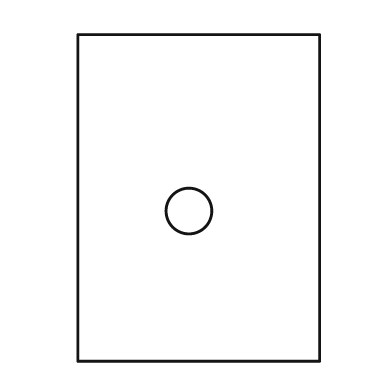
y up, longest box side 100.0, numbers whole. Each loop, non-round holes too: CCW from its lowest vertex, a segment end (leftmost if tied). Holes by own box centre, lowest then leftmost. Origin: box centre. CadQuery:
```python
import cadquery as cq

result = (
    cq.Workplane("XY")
    .moveTo(-37.0, -50.0)
    .lineTo(37.0, -50.0)
    .lineTo(37.0, 50.0)
    .lineTo(-37.0, 50.0)
    .close()
    .moveTo(-3.0, -4.0)
    .circle(7.0)
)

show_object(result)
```